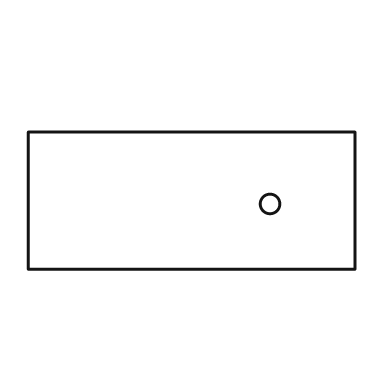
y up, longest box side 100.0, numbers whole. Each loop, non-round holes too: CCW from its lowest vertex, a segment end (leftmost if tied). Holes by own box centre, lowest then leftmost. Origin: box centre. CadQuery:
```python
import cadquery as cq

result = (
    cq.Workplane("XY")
    .moveTo(-50.0, -21.0)
    .lineTo(50.0, -21.0)
    .lineTo(50.0, 21.0)
    .lineTo(-50.0, 21.0)
    .close()
    .moveTo(24.0, -1.0)
    .circle(3.0)
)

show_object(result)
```